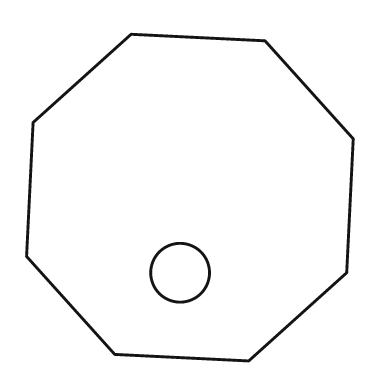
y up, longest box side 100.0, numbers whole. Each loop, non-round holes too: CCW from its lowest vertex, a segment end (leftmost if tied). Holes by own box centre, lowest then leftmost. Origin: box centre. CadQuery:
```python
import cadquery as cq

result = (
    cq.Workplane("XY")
    .moveTo(18.0, -50.0)
    .lineTo(48.0, -23.0)
    .lineTo(50.0, 18.0)
    .lineTo(23.0, 48.0)
    .lineTo(-18.0, 50.0)
    .lineTo(-48.0, 23.0)
    .lineTo(-50.0, -18.0)
    .lineTo(-23.0, -48.0)
    .close()
    .moveTo(-3.0, -23.0)
    .circle(9.0)
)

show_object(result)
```